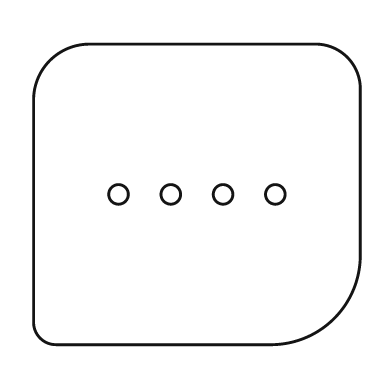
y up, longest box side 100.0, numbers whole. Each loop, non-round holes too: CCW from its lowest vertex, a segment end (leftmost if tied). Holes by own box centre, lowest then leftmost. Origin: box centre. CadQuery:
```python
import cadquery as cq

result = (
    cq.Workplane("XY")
    .moveTo(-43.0, -46.0)
    .lineTo(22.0, -46.0)
    .threePointArc((42.0, -38.0), (50.0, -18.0))
    .lineTo(50.0, 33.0)
    .threePointArc((46.0, 42.0), (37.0, 46.0))
    .lineTo(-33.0, 46.0)
    .threePointArc((-45.0, 41.0), (-50.0, 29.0))
    .lineTo(-50.0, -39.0)
    .threePointArc((-48.0, -44.0), (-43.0, -46.0))
    .close()
    .moveTo(-24.0, 0.0)
    .circle(3.0)
    .moveTo(-8.0, 0.0)
    .circle(3.0)
    .moveTo(8.0, 0.0)
    .circle(3.0)
    .moveTo(24.0, 0.0)
    .circle(3.0)
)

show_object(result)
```